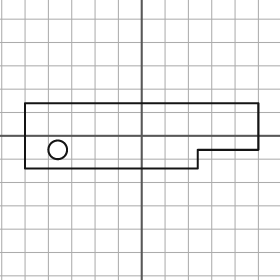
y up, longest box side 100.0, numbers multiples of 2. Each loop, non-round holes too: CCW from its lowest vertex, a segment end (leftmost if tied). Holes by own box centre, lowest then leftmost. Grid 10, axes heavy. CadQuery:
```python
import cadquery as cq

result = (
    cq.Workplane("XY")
    .moveTo(-50.0, -14.0)
    .lineTo(24.0, -14.0)
    .lineTo(24.0, -6.0)
    .lineTo(50.0, -6.0)
    .lineTo(50.0, 14.0)
    .lineTo(-50.0, 14.0)
    .close()
    .moveTo(-36.0, -6.0)
    .circle(4.0)
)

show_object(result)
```